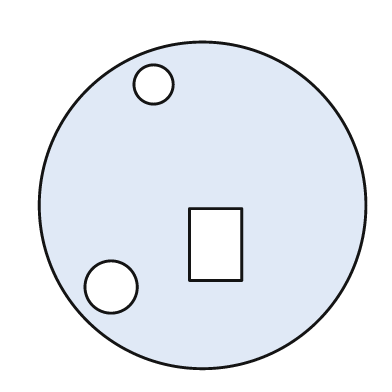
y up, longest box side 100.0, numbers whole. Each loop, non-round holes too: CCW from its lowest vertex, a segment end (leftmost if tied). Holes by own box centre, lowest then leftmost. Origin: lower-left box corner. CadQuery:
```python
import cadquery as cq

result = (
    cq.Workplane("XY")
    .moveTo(50.0, 50.0)
    .circle(50.0)
    .moveTo(22.0, 25.0)
    .circle(8.0)
    .moveTo(46.0, 27.0)
    .lineTo(62.0, 27.0)
    .lineTo(62.0, 49.0)
    .lineTo(46.0, 49.0)
    .close()
    .moveTo(35.0, 87.0)
    .circle(6.0)
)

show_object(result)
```